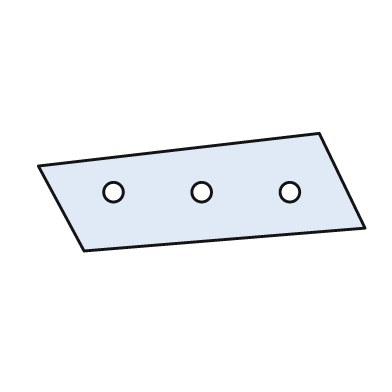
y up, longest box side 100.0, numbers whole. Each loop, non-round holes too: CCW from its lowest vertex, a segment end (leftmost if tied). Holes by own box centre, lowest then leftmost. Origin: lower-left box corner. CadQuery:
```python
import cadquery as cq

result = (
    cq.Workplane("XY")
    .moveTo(14.0, 0.0)
    .lineTo(100.0, 7.0)
    .lineTo(86.0, 36.0)
    .lineTo(0.0, 26.0)
    .close()
    .moveTo(23.0, 18.0)
    .circle(3.0)
    .moveTo(50.0, 18.0)
    .circle(3.0)
    .moveTo(77.0, 18.0)
    .circle(3.0)
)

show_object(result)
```